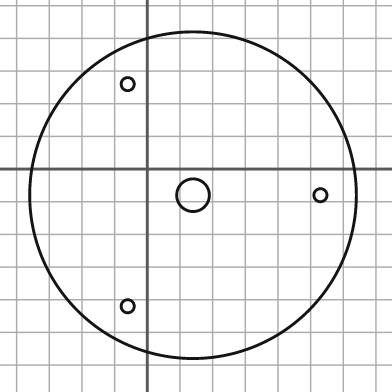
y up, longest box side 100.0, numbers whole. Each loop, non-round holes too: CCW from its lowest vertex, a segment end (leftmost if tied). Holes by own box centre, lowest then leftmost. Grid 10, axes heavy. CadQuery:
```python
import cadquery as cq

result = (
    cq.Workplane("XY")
    .moveTo(14.0, -8.0)
    .circle(50.0)
    .moveTo(-6.0, -42.0)
    .circle(2.0)
    .moveTo(14.0, -8.0)
    .circle(5.0)
    .moveTo(53.0, -8.0)
    .circle(2.0)
    .moveTo(-6.0, 26.0)
    .circle(2.0)
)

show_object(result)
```